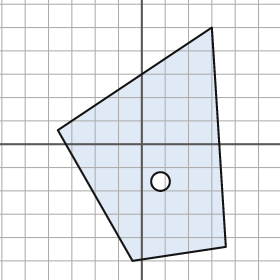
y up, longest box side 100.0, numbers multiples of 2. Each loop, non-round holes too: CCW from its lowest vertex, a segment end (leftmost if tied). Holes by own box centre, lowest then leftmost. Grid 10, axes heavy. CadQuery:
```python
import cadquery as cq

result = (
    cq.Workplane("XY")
    .moveTo(-4.0, -50.0)
    .lineTo(36.0, -44.0)
    .lineTo(30.0, 50.0)
    .lineTo(-36.0, 6.0)
    .close()
    .moveTo(8.0, -16.0)
    .circle(4.0)
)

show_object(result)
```